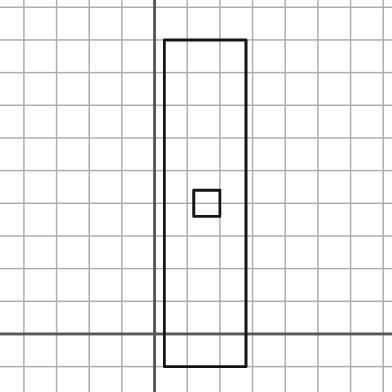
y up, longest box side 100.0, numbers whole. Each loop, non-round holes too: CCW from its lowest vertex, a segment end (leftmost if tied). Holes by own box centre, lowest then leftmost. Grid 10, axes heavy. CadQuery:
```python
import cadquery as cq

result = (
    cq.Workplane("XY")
    .moveTo(3.0, -10.0)
    .lineTo(28.0, -10.0)
    .lineTo(28.0, 90.0)
    .lineTo(3.0, 90.0)
    .close()
    .moveTo(12.0, 36.0)
    .lineTo(20.0, 36.0)
    .lineTo(20.0, 44.0)
    .lineTo(12.0, 44.0)
    .close()
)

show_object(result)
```